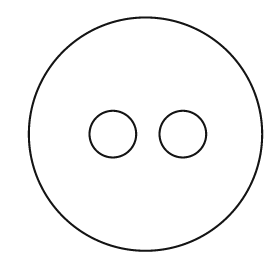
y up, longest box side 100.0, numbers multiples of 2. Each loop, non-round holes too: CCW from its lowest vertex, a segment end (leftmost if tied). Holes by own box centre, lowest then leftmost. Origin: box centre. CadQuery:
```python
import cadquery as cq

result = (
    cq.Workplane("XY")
    .moveTo(0.0, 0.0)
    .circle(50.0)
    .moveTo(-14.0, 0.0)
    .circle(10.0)
    .moveTo(16.0, 0.0)
    .circle(10.0)
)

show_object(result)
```